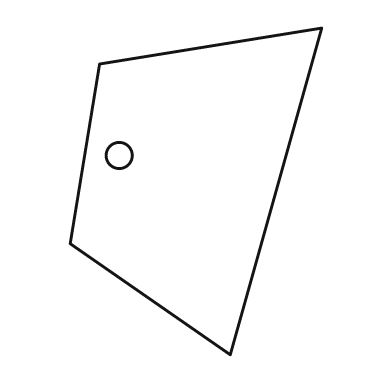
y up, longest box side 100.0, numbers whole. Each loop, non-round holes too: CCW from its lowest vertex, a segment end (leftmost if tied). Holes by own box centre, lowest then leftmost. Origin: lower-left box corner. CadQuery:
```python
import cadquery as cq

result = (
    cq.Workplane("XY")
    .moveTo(49.0, 0.0)
    .lineTo(77.0, 100.0)
    .lineTo(9.0, 89.0)
    .lineTo(0.0, 34.0)
    .close()
    .moveTo(15.0, 61.0)
    .circle(4.0)
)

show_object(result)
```